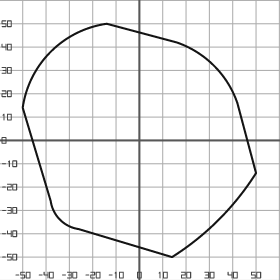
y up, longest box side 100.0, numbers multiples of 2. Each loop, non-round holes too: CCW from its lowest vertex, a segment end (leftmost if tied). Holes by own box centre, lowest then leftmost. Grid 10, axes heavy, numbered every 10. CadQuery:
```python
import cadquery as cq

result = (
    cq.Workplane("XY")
    .moveTo(14.0, -50.0)
    .threePointArc((34.0, -34.0), (50.0, -14.0))
    .lineTo(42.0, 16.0)
    .threePointArc((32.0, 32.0), (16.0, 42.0))
    .lineTo(-14.0, 50.0)
    .threePointArc((-38.0, 38.0), (-50.0, 14.0))
    .lineTo(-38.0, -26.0)
    .threePointArc((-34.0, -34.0), (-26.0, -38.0))
    .close()
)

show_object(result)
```